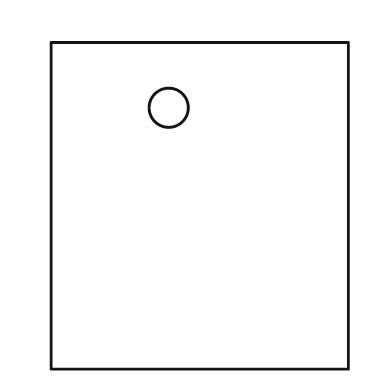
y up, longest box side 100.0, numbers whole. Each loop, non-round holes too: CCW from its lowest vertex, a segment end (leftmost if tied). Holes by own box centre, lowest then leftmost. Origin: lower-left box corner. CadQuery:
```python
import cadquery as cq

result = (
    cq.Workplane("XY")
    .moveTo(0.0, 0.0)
    .lineTo(91.0, 0.0)
    .lineTo(91.0, 100.0)
    .lineTo(0.0, 100.0)
    .close()
    .moveTo(36.0, 80.0)
    .circle(6.0)
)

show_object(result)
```